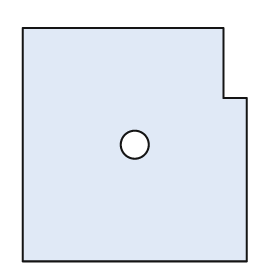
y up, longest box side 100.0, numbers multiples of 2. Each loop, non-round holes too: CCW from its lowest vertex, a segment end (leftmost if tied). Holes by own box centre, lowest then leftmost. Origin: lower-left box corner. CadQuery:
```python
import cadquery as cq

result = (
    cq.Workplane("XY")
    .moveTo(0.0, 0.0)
    .lineTo(96.0, 0.0)
    .lineTo(96.0, 70.0)
    .lineTo(86.0, 70.0)
    .lineTo(86.0, 100.0)
    .lineTo(0.0, 100.0)
    .close()
    .moveTo(48.0, 50.0)
    .circle(6.0)
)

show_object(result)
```